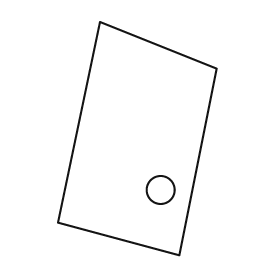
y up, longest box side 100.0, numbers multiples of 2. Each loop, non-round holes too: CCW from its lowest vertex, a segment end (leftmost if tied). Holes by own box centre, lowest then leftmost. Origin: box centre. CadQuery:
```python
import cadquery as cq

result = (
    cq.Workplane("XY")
    .moveTo(18.0, -50.0)
    .lineTo(34.0, 30.0)
    .lineTo(-16.0, 50.0)
    .lineTo(-34.0, -36.0)
    .close()
    .moveTo(10.0, -22.0)
    .circle(6.0)
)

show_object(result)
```